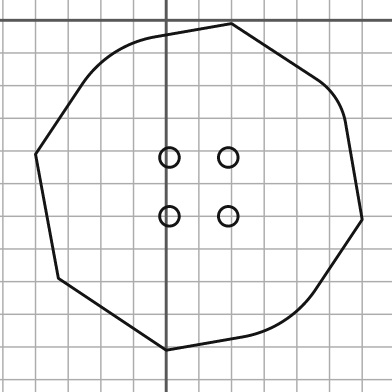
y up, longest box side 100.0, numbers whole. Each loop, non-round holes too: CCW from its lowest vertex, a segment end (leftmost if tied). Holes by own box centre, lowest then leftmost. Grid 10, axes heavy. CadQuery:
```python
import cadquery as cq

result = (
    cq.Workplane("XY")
    .moveTo(0.0, -101.0)
    .lineTo(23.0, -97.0)
    .threePointArc((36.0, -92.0), (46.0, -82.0))
    .lineTo(60.0, -61.0)
    .lineTo(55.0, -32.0)
    .threePointArc((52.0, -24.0), (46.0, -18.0))
    .lineTo(20.0, -1.0)
    .lineTo(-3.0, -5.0)
    .threePointArc((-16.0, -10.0), (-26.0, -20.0))
    .lineTo(-40.0, -41.0)
    .lineTo(-33.0, -79.0)
    .close()
    .moveTo(1.0, -60.0)
    .circle(3.0)
    .moveTo(19.0, -60.0)
    .circle(3.0)
    .moveTo(1.0, -42.0)
    .circle(3.0)
    .moveTo(19.0, -42.0)
    .circle(3.0)
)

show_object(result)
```